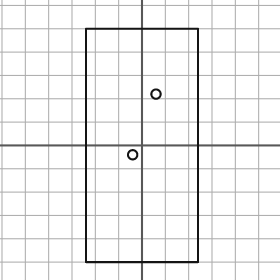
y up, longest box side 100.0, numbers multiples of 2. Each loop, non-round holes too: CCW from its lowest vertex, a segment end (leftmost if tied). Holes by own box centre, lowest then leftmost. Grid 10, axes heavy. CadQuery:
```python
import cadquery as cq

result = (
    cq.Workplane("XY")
    .moveTo(-24.0, -50.0)
    .lineTo(24.0, -50.0)
    .lineTo(24.0, 50.0)
    .lineTo(-24.0, 50.0)
    .close()
    .moveTo(-4.0, -4.0)
    .circle(2.0)
    .moveTo(6.0, 22.0)
    .circle(2.0)
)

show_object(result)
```